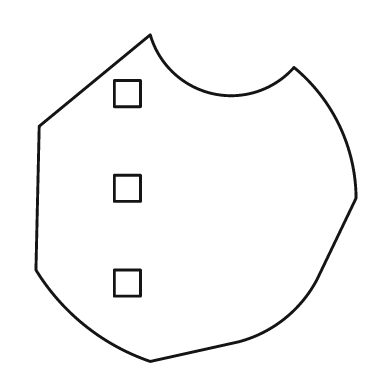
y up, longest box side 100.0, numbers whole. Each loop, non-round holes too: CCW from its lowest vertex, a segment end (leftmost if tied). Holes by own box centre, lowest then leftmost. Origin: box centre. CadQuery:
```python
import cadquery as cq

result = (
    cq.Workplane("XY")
    .moveTo(-14.0, -50.0)
    .lineTo(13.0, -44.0)
    .threePointArc((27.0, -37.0), (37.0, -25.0))
    .lineTo(49.0, 0.0)
    .threePointArc((44.0, 22.0), (30.0, 40.0))
    .threePointArc((5.0, 32.0), (-14.0, 50.0))
    .lineTo(-48.0, 22.0)
    .lineTo(-49.0, -22.0)
    .threePointArc((-34.0, -39.0), (-14.0, -50.0))
    .close()
    .moveTo(-25.0, -30.0)
    .lineTo(-17.0, -30.0)
    .lineTo(-17.0, -22.0)
    .lineTo(-25.0, -22.0)
    .close()
    .moveTo(-25.0, -1.0)
    .lineTo(-17.0, -1.0)
    .lineTo(-17.0, 7.0)
    .lineTo(-25.0, 7.0)
    .close()
    .moveTo(-25.0, 28.0)
    .lineTo(-17.0, 28.0)
    .lineTo(-17.0, 36.0)
    .lineTo(-25.0, 36.0)
    .close()
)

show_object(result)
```